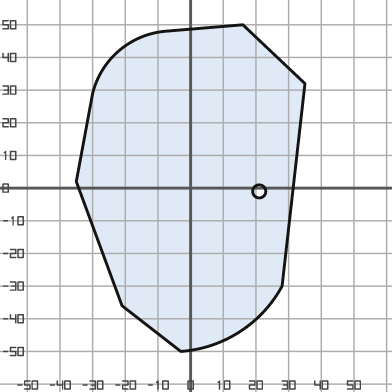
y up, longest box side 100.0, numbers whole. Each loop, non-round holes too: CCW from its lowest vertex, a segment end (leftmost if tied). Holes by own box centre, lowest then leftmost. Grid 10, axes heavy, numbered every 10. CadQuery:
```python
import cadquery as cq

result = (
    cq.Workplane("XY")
    .moveTo(-3.0, -50.0)
    .threePointArc((15.0, -44.0), (28.0, -30.0))
    .lineTo(35.0, 32.0)
    .lineTo(16.0, 50.0)
    .lineTo(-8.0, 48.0)
    .threePointArc((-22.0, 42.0), (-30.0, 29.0))
    .lineTo(-35.0, 2.0)
    .lineTo(-21.0, -36.0)
    .close()
    .moveTo(21.0, -1.0)
    .circle(2.0)
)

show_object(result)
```